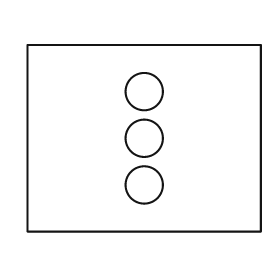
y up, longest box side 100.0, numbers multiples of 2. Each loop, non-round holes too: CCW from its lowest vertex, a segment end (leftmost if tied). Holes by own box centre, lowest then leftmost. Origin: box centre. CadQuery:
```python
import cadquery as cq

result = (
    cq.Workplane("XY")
    .moveTo(-50.0, -40.0)
    .lineTo(50.0, -40.0)
    .lineTo(50.0, 40.0)
    .lineTo(-50.0, 40.0)
    .close()
    .moveTo(0.0, -20.0)
    .circle(8.0)
    .moveTo(0.0, 0.0)
    .circle(8.0)
    .moveTo(0.0, 20.0)
    .circle(8.0)
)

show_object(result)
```